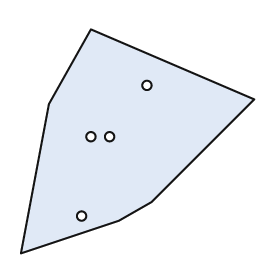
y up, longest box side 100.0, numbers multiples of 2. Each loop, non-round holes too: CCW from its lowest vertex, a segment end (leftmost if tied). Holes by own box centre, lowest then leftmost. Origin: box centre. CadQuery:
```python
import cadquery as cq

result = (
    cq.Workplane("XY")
    .moveTo(-50.0, -48.0)
    .lineTo(-8.0, -34.0)
    .lineTo(6.0, -26.0)
    .lineTo(50.0, 18.0)
    .lineTo(-20.0, 48.0)
    .lineTo(-38.0, 16.0)
    .close()
    .moveTo(-24.0, -32.0)
    .circle(2.0)
    .moveTo(-20.0, 2.0)
    .circle(2.0)
    .moveTo(-12.0, 2.0)
    .circle(2.0)
    .moveTo(4.0, 24.0)
    .circle(2.0)
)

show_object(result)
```